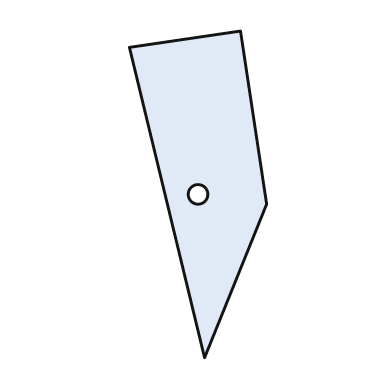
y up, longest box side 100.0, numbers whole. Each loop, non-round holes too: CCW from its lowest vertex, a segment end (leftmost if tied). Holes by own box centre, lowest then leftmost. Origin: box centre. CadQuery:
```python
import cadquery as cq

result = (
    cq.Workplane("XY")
    .moveTo(2.0, -50.0)
    .lineTo(21.0, -3.0)
    .lineTo(13.0, 50.0)
    .lineTo(-21.0, 45.0)
    .close()
    .moveTo(0.0, 0.0)
    .circle(3.0)
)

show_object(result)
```